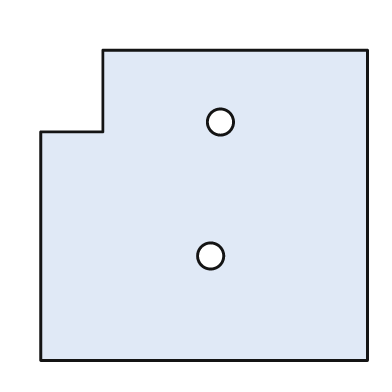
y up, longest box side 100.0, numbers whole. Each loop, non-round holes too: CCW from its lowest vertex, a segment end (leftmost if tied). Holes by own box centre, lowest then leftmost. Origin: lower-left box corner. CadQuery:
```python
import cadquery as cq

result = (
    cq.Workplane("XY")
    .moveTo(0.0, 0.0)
    .lineTo(100.0, 0.0)
    .lineTo(100.0, 95.0)
    .lineTo(19.0, 95.0)
    .lineTo(19.0, 70.0)
    .lineTo(0.0, 70.0)
    .close()
    .moveTo(52.0, 32.0)
    .circle(4.0)
    .moveTo(55.0, 73.0)
    .circle(4.0)
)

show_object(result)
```